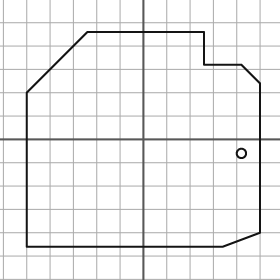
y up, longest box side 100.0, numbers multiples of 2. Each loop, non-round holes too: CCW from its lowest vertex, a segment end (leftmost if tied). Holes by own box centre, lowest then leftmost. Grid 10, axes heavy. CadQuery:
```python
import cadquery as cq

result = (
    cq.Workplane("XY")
    .moveTo(-50.0, -46.0)
    .lineTo(34.0, -46.0)
    .lineTo(50.0, -40.0)
    .lineTo(50.0, 24.0)
    .lineTo(42.0, 32.0)
    .lineTo(26.0, 32.0)
    .lineTo(26.0, 46.0)
    .lineTo(-24.0, 46.0)
    .lineTo(-50.0, 20.0)
    .close()
    .moveTo(42.0, -6.0)
    .circle(2.0)
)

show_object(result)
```